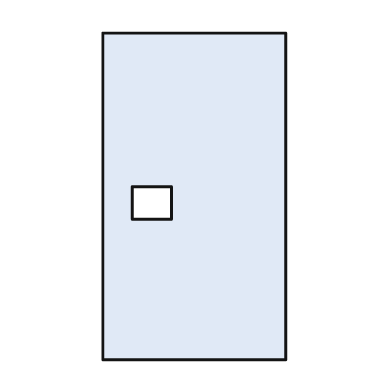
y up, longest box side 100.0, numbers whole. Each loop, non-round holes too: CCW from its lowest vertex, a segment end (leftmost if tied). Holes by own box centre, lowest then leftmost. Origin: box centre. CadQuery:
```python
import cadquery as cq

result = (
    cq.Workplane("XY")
    .moveTo(-28.0, -50.0)
    .lineTo(28.0, -50.0)
    .lineTo(28.0, 50.0)
    .lineTo(-28.0, 50.0)
    .close()
    .moveTo(-19.0, -7.0)
    .lineTo(-7.0, -7.0)
    .lineTo(-7.0, 3.0)
    .lineTo(-19.0, 3.0)
    .close()
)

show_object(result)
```